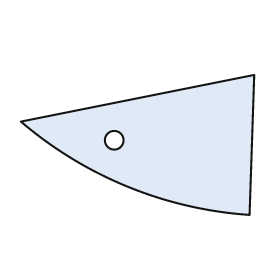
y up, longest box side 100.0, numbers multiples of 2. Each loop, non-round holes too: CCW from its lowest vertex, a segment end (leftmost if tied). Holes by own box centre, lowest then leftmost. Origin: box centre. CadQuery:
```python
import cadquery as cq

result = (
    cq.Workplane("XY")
    .moveTo(48.0, -30.0)
    .lineTo(50.0, 30.0)
    .lineTo(-50.0, 10.0)
    .threePointArc((-4.0, -18.0), (48.0, -30.0))
    .close()
    .moveTo(-10.0, 2.0)
    .circle(4.0)
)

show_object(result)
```